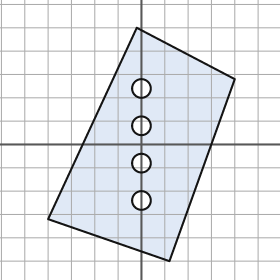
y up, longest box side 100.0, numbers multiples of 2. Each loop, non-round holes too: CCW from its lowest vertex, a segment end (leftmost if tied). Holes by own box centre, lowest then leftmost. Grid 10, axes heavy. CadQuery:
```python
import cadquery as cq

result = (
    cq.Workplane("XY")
    .moveTo(12.0, -50.0)
    .lineTo(40.0, 28.0)
    .lineTo(-2.0, 50.0)
    .lineTo(-40.0, -32.0)
    .close()
    .moveTo(0.0, -24.0)
    .circle(4.0)
    .moveTo(0.0, -8.0)
    .circle(4.0)
    .moveTo(0.0, 8.0)
    .circle(4.0)
    .moveTo(0.0, 24.0)
    .circle(4.0)
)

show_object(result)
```